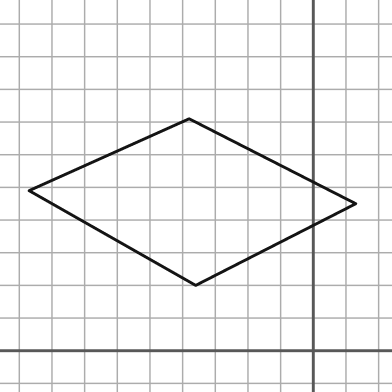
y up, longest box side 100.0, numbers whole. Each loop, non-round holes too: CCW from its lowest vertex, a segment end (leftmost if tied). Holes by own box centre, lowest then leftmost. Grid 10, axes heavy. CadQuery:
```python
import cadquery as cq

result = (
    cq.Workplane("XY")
    .moveTo(-36.0, 20.0)
    .lineTo(13.0, 45.0)
    .lineTo(-38.0, 71.0)
    .lineTo(-87.0, 49.0)
    .close()
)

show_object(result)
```